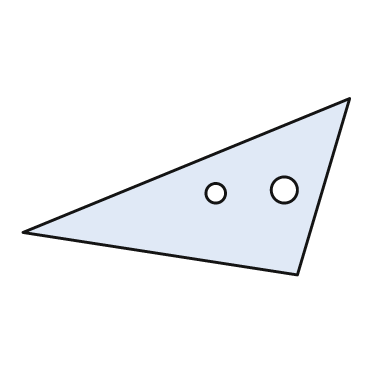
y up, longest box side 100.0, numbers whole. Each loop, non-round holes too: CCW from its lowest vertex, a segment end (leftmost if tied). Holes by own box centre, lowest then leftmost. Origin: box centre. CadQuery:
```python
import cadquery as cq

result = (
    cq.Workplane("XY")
    .moveTo(34.0, -27.0)
    .lineTo(50.0, 27.0)
    .lineTo(-50.0, -14.0)
    .close()
    .moveTo(9.0, -2.0)
    .circle(3.0)
    .moveTo(30.0, -1.0)
    .circle(4.0)
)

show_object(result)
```